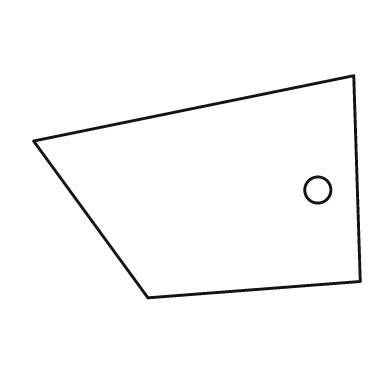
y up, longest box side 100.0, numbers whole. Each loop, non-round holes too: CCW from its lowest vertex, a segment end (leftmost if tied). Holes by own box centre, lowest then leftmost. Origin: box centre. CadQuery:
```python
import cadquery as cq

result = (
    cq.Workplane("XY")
    .moveTo(-15.0, -34.0)
    .lineTo(50.0, -29.0)
    .lineTo(48.0, 34.0)
    .lineTo(-50.0, 14.0)
    .close()
    .moveTo(37.0, -1.0)
    .circle(4.0)
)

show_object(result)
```